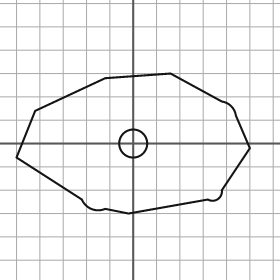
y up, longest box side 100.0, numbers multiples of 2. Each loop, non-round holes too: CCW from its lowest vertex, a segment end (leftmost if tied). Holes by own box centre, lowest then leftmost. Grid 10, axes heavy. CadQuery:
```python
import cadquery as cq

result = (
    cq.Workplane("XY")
    .moveTo(-2.0, -30.0)
    .lineTo(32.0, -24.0)
    .threePointArc((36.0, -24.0), (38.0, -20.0))
    .lineTo(50.0, -2.0)
    .lineTo(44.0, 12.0)
    .threePointArc((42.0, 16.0), (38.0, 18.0))
    .lineTo(16.0, 30.0)
    .lineTo(-12.0, 28.0)
    .lineTo(-42.0, 14.0)
    .lineTo(-50.0, -6.0)
    .lineTo(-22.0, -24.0)
    .threePointArc((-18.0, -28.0), (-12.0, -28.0))
    .close()
    .moveTo(0.0, 0.0)
    .circle(6.0)
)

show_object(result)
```